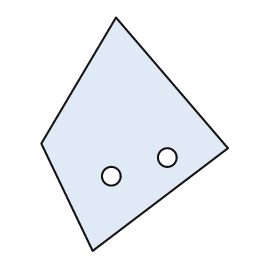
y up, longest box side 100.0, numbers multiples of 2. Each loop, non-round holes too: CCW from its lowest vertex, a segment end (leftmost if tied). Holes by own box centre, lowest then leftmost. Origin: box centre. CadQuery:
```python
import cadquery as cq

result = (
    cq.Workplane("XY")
    .moveTo(-18.0, -50.0)
    .lineTo(40.0, -6.0)
    .lineTo(-8.0, 50.0)
    .lineTo(-40.0, -4.0)
    .close()
    .moveTo(-10.0, -18.0)
    .circle(4.0)
    .moveTo(14.0, -10.0)
    .circle(4.0)
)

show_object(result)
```